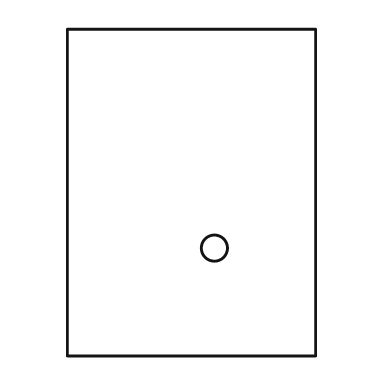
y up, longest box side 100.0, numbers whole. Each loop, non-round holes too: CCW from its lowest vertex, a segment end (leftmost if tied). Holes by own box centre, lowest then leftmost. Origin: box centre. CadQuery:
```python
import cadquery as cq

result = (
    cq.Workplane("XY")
    .moveTo(-38.0, -50.0)
    .lineTo(38.0, -50.0)
    .lineTo(38.0, 50.0)
    .lineTo(-38.0, 50.0)
    .close()
    .moveTo(7.0, -17.0)
    .circle(4.0)
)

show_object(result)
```